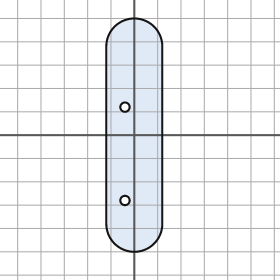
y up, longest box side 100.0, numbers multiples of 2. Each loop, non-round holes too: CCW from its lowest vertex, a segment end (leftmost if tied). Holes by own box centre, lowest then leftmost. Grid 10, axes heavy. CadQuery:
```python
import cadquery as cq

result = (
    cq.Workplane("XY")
    .moveTo(-12.0, -38.0)
    .threePointArc((0.0, -50.0), (12.0, -38.0))
    .lineTo(12.0, 38.0)
    .threePointArc((0.0, 50.0), (-12.0, 38.0))
    .close()
    .moveTo(-4.0, -28.0)
    .circle(2.0)
    .moveTo(-4.0, 12.0)
    .circle(2.0)
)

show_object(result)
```